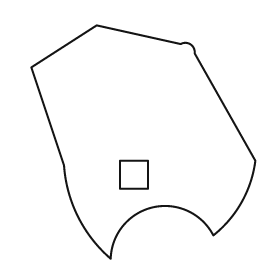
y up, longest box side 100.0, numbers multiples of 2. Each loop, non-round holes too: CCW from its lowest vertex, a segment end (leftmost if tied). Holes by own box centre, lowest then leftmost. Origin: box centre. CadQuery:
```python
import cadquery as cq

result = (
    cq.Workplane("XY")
    .moveTo(-14.0, -50.0)
    .threePointArc((4.0, -28.0), (30.0, -40.0))
    .threePointArc((42.0, -26.0), (48.0, -8.0))
    .lineTo(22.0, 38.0)
    .threePointArc((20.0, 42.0), (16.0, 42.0))
    .lineTo(-20.0, 50.0)
    .lineTo(-48.0, 32.0)
    .lineTo(-34.0, -10.0)
    .threePointArc((-28.0, -32.0), (-14.0, -50.0))
    .close()
    .moveTo(-10.0, -20.0)
    .lineTo(2.0, -20.0)
    .lineTo(2.0, -8.0)
    .lineTo(-10.0, -8.0)
    .close()
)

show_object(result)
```